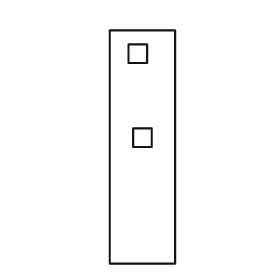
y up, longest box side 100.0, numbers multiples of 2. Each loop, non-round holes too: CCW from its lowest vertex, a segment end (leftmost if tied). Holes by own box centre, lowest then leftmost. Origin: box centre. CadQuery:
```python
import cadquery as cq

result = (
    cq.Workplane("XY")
    .moveTo(-14.0, -50.0)
    .lineTo(14.0, -50.0)
    .lineTo(14.0, 50.0)
    .lineTo(-14.0, 50.0)
    .close()
    .moveTo(-4.0, 0.0)
    .lineTo(4.0, 0.0)
    .lineTo(4.0, 8.0)
    .lineTo(-4.0, 8.0)
    .close()
    .moveTo(-6.0, 36.0)
    .lineTo(2.0, 36.0)
    .lineTo(2.0, 44.0)
    .lineTo(-6.0, 44.0)
    .close()
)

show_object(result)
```